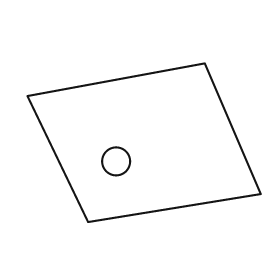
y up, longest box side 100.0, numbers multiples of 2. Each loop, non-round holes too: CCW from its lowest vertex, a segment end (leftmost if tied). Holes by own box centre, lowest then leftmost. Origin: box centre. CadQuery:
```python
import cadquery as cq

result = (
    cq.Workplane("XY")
    .moveTo(-24.0, -34.0)
    .lineTo(50.0, -22.0)
    .lineTo(26.0, 34.0)
    .lineTo(-50.0, 20.0)
    .close()
    .moveTo(-12.0, -8.0)
    .circle(6.0)
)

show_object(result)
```